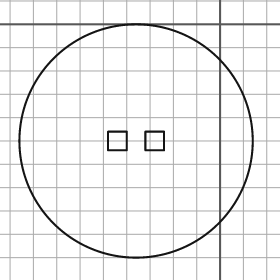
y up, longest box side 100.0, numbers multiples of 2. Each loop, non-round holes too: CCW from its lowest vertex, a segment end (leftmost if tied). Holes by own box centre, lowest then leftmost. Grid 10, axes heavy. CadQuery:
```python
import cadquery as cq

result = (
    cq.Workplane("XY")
    .moveTo(-36.0, -50.0)
    .circle(50.0)
    .moveTo(-48.0, -54.0)
    .lineTo(-40.0, -54.0)
    .lineTo(-40.0, -46.0)
    .lineTo(-48.0, -46.0)
    .close()
    .moveTo(-32.0, -54.0)
    .lineTo(-24.0, -54.0)
    .lineTo(-24.0, -46.0)
    .lineTo(-32.0, -46.0)
    .close()
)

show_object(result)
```